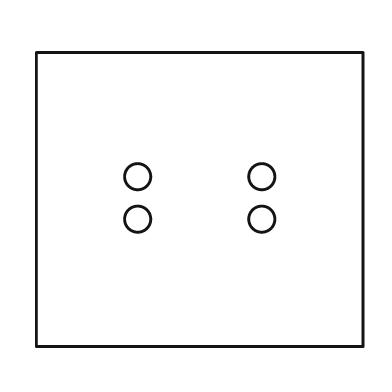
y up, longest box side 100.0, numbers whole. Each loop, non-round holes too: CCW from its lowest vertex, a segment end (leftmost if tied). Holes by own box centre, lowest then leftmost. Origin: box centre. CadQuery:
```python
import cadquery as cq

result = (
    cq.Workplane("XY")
    .moveTo(-50.0, -45.0)
    .lineTo(50.0, -45.0)
    .lineTo(50.0, 45.0)
    .lineTo(-50.0, 45.0)
    .close()
    .moveTo(-19.0, -6.0)
    .circle(4.0)
    .moveTo(19.0, -6.0)
    .circle(4.0)
    .moveTo(-19.0, 7.0)
    .circle(4.0)
    .moveTo(19.0, 7.0)
    .circle(4.0)
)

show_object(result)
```